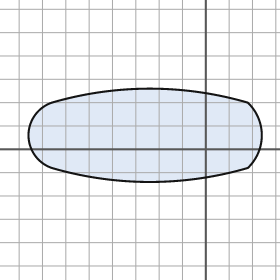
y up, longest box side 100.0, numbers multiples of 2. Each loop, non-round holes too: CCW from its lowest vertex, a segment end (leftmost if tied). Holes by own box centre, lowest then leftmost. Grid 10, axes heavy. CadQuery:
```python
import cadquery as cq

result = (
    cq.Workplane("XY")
    .moveTo(-66.0, -8.0)
    .threePointArc((-24.0, -14.0), (18.0, -8.0))
    .threePointArc((24.0, 6.0), (18.0, 20.0))
    .threePointArc((-24.0, 26.0), (-66.0, 20.0))
    .threePointArc((-76.0, 6.0), (-66.0, -8.0))
    .close()
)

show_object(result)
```